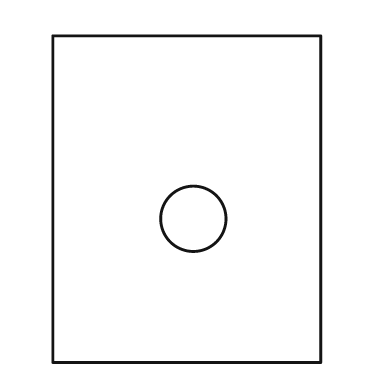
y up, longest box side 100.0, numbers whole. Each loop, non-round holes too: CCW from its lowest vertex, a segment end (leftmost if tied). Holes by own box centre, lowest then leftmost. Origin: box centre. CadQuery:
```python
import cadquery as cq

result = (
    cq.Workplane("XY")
    .moveTo(-41.0, -50.0)
    .lineTo(41.0, -50.0)
    .lineTo(41.0, 50.0)
    .lineTo(-41.0, 50.0)
    .close()
    .moveTo(2.0, -6.0)
    .circle(10.0)
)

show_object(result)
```